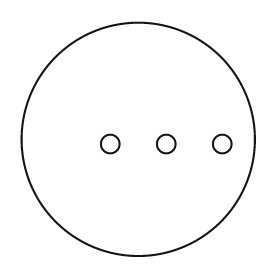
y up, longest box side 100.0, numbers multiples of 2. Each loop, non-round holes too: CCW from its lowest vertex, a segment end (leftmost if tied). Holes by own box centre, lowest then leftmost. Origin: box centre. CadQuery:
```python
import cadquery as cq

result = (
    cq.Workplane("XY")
    .moveTo(0.0, 0.0)
    .circle(50.0)
    .moveTo(-12.0, -2.0)
    .circle(4.0)
    .moveTo(12.0, -2.0)
    .circle(4.0)
    .moveTo(36.0, -2.0)
    .circle(4.0)
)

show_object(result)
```